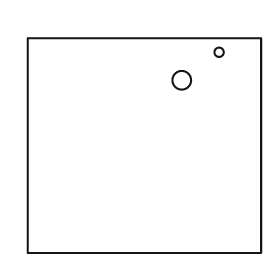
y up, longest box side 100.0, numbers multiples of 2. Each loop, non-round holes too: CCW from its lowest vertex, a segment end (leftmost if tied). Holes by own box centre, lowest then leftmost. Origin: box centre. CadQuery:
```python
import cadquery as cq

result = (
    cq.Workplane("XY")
    .moveTo(-50.0, -46.0)
    .lineTo(50.0, -46.0)
    .lineTo(50.0, 46.0)
    .lineTo(-50.0, 46.0)
    .close()
    .moveTo(16.0, 28.0)
    .circle(4.0)
    .moveTo(32.0, 40.0)
    .circle(2.0)
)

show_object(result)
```